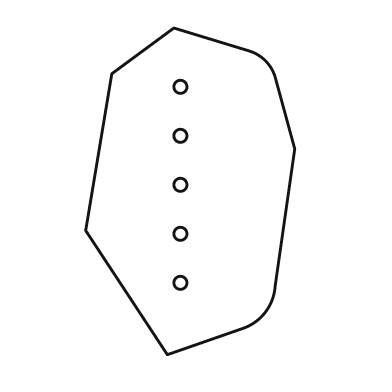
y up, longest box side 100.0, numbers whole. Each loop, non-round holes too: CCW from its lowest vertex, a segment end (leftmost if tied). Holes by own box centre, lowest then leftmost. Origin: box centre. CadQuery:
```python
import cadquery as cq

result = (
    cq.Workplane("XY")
    .moveTo(-7.0, -50.0)
    .lineTo(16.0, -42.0)
    .threePointArc((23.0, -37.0), (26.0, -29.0))
    .lineTo(32.0, 13.0)
    .lineTo(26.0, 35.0)
    .threePointArc((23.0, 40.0), (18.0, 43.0))
    .lineTo(-5.0, 50.0)
    .lineTo(-24.0, 36.0)
    .lineTo(-32.0, -12.0)
    .close()
    .moveTo(-3.0, -28.0)
    .circle(2.0)
    .moveTo(-3.0, -13.0)
    .circle(2.0)
    .moveTo(-3.0, 2.0)
    .circle(2.0)
    .moveTo(-3.0, 17.0)
    .circle(2.0)
    .moveTo(-3.0, 32.0)
    .circle(2.0)
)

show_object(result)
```